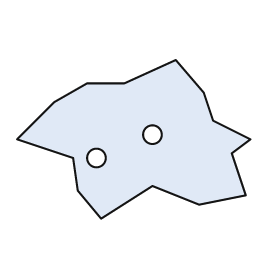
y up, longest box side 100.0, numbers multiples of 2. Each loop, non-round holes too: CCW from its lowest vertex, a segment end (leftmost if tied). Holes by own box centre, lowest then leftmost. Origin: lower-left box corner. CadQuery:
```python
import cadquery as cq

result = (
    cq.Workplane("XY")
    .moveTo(36.0, 0.0)
    .lineTo(58.0, 14.0)
    .lineTo(78.0, 6.0)
    .lineTo(98.0, 10.0)
    .lineTo(92.0, 28.0)
    .lineTo(100.0, 34.0)
    .lineTo(84.0, 42.0)
    .lineTo(80.0, 54.0)
    .lineTo(68.0, 68.0)
    .lineTo(46.0, 58.0)
    .lineTo(30.0, 58.0)
    .lineTo(16.0, 50.0)
    .lineTo(0.0, 34.0)
    .lineTo(24.0, 26.0)
    .lineTo(26.0, 12.0)
    .close()
    .moveTo(34.0, 26.0)
    .circle(4.0)
    .moveTo(58.0, 36.0)
    .circle(4.0)
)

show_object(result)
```